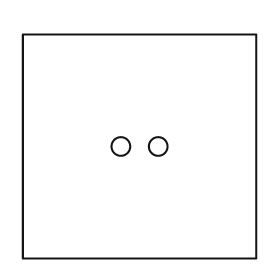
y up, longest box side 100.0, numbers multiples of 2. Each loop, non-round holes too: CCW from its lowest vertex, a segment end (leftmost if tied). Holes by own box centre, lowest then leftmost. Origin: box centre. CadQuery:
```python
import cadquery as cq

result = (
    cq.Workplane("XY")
    .moveTo(-50.0, -48.0)
    .lineTo(50.0, -48.0)
    .lineTo(50.0, 48.0)
    .lineTo(-50.0, 48.0)
    .close()
    .moveTo(-8.0, 0.0)
    .circle(4.0)
    .moveTo(8.0, 0.0)
    .circle(4.0)
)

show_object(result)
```